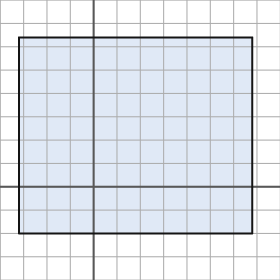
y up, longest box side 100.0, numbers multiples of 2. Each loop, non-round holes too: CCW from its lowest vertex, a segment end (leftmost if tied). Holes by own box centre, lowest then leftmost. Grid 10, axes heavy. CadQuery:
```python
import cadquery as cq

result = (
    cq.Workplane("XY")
    .moveTo(-32.0, -20.0)
    .lineTo(68.0, -20.0)
    .lineTo(68.0, 64.0)
    .lineTo(-32.0, 64.0)
    .close()
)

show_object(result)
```